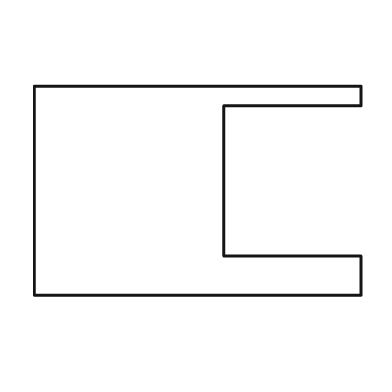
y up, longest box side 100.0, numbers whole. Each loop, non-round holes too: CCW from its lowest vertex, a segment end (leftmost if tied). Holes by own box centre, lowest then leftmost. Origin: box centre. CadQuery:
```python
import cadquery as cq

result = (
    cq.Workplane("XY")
    .moveTo(-50.0, -32.0)
    .lineTo(50.0, -32.0)
    .lineTo(50.0, -20.0)
    .lineTo(8.0, -20.0)
    .lineTo(8.0, 26.0)
    .lineTo(50.0, 26.0)
    .lineTo(50.0, 32.0)
    .lineTo(-50.0, 32.0)
    .close()
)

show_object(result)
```